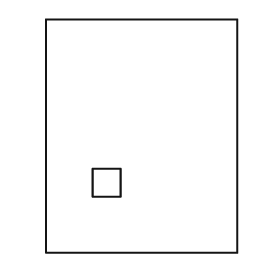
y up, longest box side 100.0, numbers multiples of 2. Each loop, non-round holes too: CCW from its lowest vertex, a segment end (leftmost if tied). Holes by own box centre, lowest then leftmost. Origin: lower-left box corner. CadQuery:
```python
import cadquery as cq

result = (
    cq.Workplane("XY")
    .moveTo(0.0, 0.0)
    .lineTo(82.0, 0.0)
    .lineTo(82.0, 100.0)
    .lineTo(0.0, 100.0)
    .close()
    .moveTo(20.0, 24.0)
    .lineTo(32.0, 24.0)
    .lineTo(32.0, 36.0)
    .lineTo(20.0, 36.0)
    .close()
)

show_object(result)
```